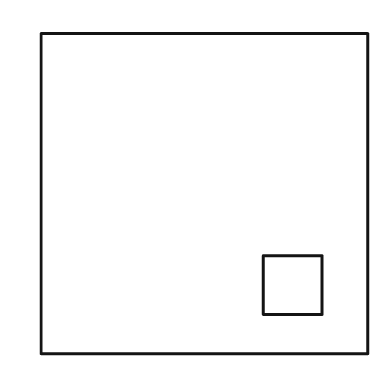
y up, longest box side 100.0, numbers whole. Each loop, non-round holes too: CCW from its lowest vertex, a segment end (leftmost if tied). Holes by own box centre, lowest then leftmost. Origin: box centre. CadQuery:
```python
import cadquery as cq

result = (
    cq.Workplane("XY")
    .moveTo(-50.0, -49.0)
    .lineTo(50.0, -49.0)
    .lineTo(50.0, 49.0)
    .lineTo(-50.0, 49.0)
    .close()
    .moveTo(18.0, -37.0)
    .lineTo(36.0, -37.0)
    .lineTo(36.0, -19.0)
    .lineTo(18.0, -19.0)
    .close()
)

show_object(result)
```